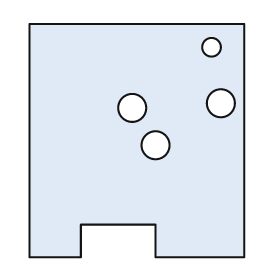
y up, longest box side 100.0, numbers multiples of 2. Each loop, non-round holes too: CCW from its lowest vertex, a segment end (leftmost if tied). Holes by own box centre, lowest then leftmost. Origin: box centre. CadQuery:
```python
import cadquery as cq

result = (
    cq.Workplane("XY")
    .moveTo(-46.0, -50.0)
    .lineTo(-24.0, -50.0)
    .lineTo(-24.0, -36.0)
    .lineTo(8.0, -36.0)
    .lineTo(8.0, -50.0)
    .lineTo(46.0, -50.0)
    .lineTo(46.0, 50.0)
    .lineTo(-46.0, 50.0)
    .close()
    .moveTo(8.0, -2.0)
    .circle(6.0)
    .moveTo(-2.0, 14.0)
    .circle(6.0)
    .moveTo(36.0, 16.0)
    .circle(6.0)
    .moveTo(32.0, 40.0)
    .circle(4.0)
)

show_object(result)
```